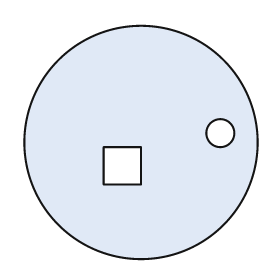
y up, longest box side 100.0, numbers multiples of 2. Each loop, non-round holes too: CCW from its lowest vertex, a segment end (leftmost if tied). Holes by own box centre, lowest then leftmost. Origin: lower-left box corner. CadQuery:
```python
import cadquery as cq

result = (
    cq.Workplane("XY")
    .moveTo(50.0, 50.0)
    .circle(50.0)
    .moveTo(34.0, 32.0)
    .lineTo(50.0, 32.0)
    .lineTo(50.0, 48.0)
    .lineTo(34.0, 48.0)
    .close()
    .moveTo(84.0, 54.0)
    .circle(6.0)
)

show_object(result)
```